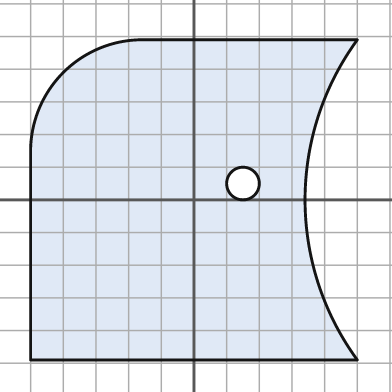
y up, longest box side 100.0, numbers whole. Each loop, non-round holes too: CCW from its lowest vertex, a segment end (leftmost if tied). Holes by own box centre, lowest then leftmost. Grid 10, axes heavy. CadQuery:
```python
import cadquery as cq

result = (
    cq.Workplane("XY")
    .moveTo(-50.0, -49.0)
    .lineTo(50.0, -49.0)
    .threePointArc((34.0, 0.0), (50.0, 49.0))
    .lineTo(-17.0, 49.0)
    .threePointArc((-40.0, 39.0), (-50.0, 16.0))
    .close()
    .moveTo(15.0, 5.0)
    .circle(5.0)
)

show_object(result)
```